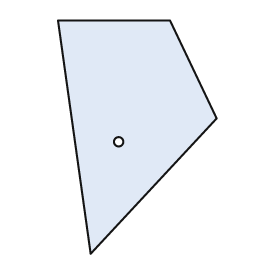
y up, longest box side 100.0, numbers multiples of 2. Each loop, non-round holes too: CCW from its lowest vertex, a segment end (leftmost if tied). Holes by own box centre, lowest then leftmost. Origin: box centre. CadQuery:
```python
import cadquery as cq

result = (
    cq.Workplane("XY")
    .moveTo(-20.0, -50.0)
    .lineTo(34.0, 8.0)
    .lineTo(14.0, 50.0)
    .lineTo(-34.0, 50.0)
    .close()
    .moveTo(-8.0, -2.0)
    .circle(2.0)
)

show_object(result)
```